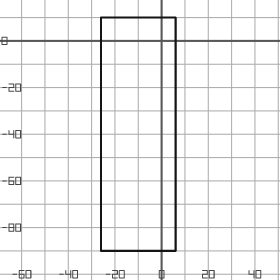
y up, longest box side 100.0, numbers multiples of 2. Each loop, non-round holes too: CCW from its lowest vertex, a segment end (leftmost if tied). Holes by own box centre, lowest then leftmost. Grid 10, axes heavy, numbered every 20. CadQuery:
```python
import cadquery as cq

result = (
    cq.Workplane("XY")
    .moveTo(-26.0, -90.0)
    .lineTo(6.0, -90.0)
    .lineTo(6.0, 10.0)
    .lineTo(-26.0, 10.0)
    .close()
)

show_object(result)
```